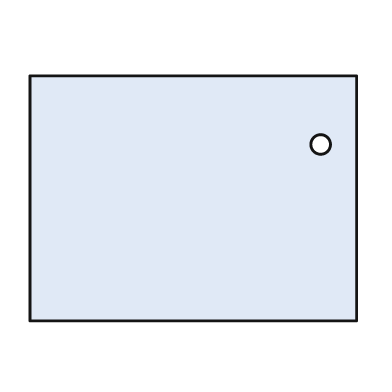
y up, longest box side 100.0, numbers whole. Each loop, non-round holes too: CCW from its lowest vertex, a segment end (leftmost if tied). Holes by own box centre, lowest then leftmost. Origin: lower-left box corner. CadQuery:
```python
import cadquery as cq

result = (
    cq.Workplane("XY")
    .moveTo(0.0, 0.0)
    .lineTo(100.0, 0.0)
    .lineTo(100.0, 75.0)
    .lineTo(0.0, 75.0)
    .close()
    .moveTo(89.0, 54.0)
    .circle(3.0)
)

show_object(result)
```